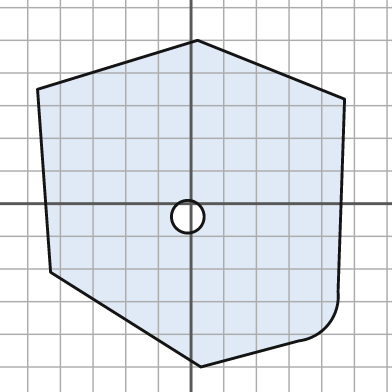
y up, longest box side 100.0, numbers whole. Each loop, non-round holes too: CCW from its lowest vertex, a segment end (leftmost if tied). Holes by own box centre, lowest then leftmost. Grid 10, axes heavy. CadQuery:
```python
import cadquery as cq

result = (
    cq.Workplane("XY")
    .moveTo(3.0, -50.0)
    .lineTo(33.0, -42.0)
    .threePointArc((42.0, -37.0), (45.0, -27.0))
    .lineTo(47.0, 32.0)
    .lineTo(2.0, 50.0)
    .lineTo(-47.0, 35.0)
    .lineTo(-43.0, -21.0)
    .close()
    .moveTo(-1.0, -4.0)
    .circle(5.0)
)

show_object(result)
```